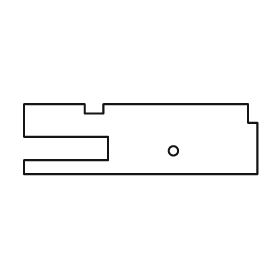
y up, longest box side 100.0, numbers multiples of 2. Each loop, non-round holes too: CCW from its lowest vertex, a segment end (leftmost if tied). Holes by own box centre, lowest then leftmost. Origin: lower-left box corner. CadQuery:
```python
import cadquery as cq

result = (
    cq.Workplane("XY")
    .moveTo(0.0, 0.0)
    .lineTo(100.0, 0.0)
    .lineTo(100.0, 22.0)
    .lineTo(96.0, 22.0)
    .lineTo(96.0, 30.0)
    .lineTo(34.0, 30.0)
    .lineTo(34.0, 26.0)
    .lineTo(26.0, 26.0)
    .lineTo(26.0, 30.0)
    .lineTo(0.0, 30.0)
    .lineTo(0.0, 16.0)
    .lineTo(36.0, 16.0)
    .lineTo(36.0, 6.0)
    .lineTo(0.0, 6.0)
    .close()
    .moveTo(64.0, 10.0)
    .circle(2.0)
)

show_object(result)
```